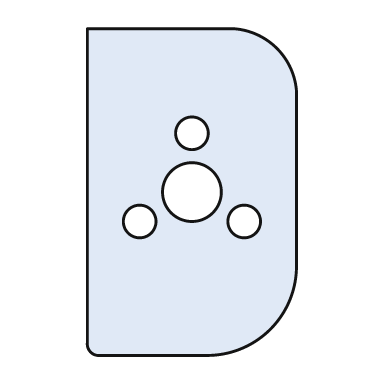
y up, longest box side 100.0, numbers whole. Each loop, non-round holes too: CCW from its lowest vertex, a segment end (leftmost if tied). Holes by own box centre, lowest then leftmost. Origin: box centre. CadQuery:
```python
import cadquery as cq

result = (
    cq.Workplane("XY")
    .moveTo(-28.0, -50.0)
    .lineTo(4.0, -50.0)
    .threePointArc((24.0, -42.0), (32.0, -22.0))
    .lineTo(32.0, 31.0)
    .threePointArc((26.0, 44.0), (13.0, 50.0))
    .lineTo(-32.0, 50.0)
    .lineTo(-32.0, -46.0)
    .threePointArc((-31.0, -49.0), (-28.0, -50.0))
    .close()
    .moveTo(-16.0, -9.0)
    .circle(5.0)
    .moveTo(16.0, -9.0)
    .circle(5.0)
    .moveTo(0.0, 0.0)
    .circle(9.0)
    .moveTo(0.0, 18.0)
    .circle(5.0)
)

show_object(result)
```